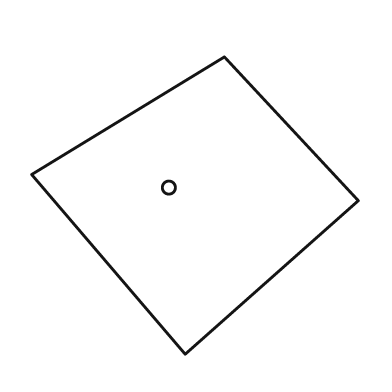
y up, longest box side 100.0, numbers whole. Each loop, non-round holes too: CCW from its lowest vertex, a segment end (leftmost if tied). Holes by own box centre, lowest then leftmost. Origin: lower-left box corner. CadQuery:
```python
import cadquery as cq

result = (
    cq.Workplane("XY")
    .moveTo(47.0, 0.0)
    .lineTo(100.0, 47.0)
    .lineTo(59.0, 91.0)
    .lineTo(0.0, 55.0)
    .close()
    .moveTo(42.0, 51.0)
    .circle(2.0)
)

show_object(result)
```